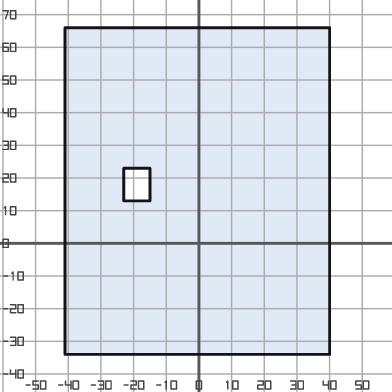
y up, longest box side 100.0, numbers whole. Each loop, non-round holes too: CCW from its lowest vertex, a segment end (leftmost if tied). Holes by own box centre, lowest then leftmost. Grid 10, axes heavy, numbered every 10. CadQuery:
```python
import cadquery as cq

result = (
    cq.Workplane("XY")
    .moveTo(-41.0, -34.0)
    .lineTo(40.0, -34.0)
    .lineTo(40.0, 66.0)
    .lineTo(-41.0, 66.0)
    .close()
    .moveTo(-23.0, 13.0)
    .lineTo(-15.0, 13.0)
    .lineTo(-15.0, 23.0)
    .lineTo(-23.0, 23.0)
    .close()
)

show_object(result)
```